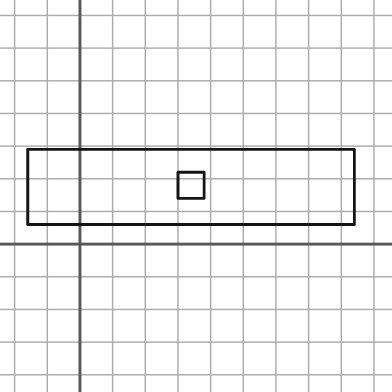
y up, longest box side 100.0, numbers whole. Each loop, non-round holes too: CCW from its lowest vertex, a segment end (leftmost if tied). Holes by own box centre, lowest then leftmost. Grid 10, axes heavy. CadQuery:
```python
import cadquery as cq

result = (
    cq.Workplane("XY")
    .moveTo(-16.0, 6.0)
    .lineTo(84.0, 6.0)
    .lineTo(84.0, 29.0)
    .lineTo(-16.0, 29.0)
    .close()
    .moveTo(30.0, 14.0)
    .lineTo(38.0, 14.0)
    .lineTo(38.0, 22.0)
    .lineTo(30.0, 22.0)
    .close()
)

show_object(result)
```